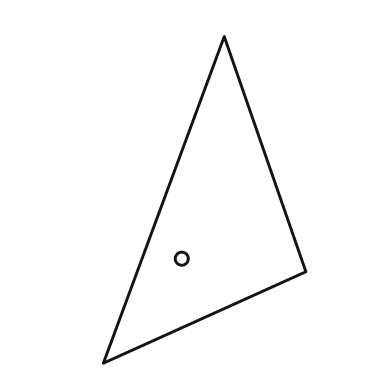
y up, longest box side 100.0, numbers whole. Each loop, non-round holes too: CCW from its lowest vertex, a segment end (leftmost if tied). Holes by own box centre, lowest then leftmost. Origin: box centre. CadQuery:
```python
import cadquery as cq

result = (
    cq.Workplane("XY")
    .moveTo(-31.0, -50.0)
    .lineTo(31.0, -22.0)
    .lineTo(6.0, 50.0)
    .close()
    .moveTo(-7.0, -18.0)
    .circle(2.0)
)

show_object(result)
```